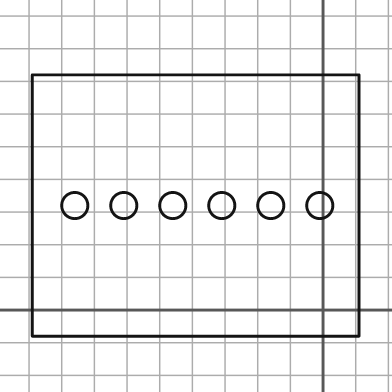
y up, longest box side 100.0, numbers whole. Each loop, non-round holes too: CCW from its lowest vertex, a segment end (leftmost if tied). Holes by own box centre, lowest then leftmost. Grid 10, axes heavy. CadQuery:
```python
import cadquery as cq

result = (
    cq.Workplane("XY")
    .moveTo(-89.0, -8.0)
    .lineTo(11.0, -8.0)
    .lineTo(11.0, 72.0)
    .lineTo(-89.0, 72.0)
    .close()
    .moveTo(-76.0, 32.0)
    .circle(4.0)
    .moveTo(-61.0, 32.0)
    .circle(4.0)
    .moveTo(-46.0, 32.0)
    .circle(4.0)
    .moveTo(-31.0, 32.0)
    .circle(4.0)
    .moveTo(-16.0, 32.0)
    .circle(4.0)
    .moveTo(-1.0, 32.0)
    .circle(4.0)
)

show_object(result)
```